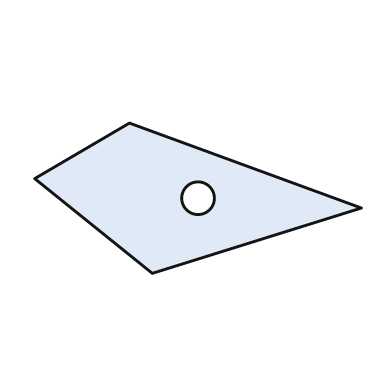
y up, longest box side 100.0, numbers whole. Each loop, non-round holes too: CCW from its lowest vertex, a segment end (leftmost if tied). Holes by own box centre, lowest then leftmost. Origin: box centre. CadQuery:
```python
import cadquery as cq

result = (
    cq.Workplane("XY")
    .moveTo(-14.0, -23.0)
    .lineTo(50.0, -3.0)
    .lineTo(-21.0, 23.0)
    .lineTo(-50.0, 6.0)
    .close()
    .moveTo(0.0, 0.0)
    .circle(5.0)
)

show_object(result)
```